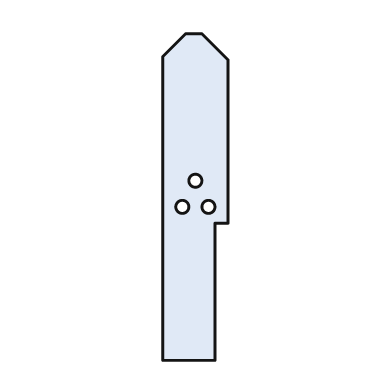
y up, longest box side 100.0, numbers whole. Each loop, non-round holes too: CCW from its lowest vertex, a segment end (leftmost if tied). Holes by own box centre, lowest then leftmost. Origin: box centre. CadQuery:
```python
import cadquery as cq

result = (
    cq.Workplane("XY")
    .moveTo(-10.0, -50.0)
    .lineTo(6.0, -50.0)
    .lineTo(6.0, -8.0)
    .lineTo(10.0, -8.0)
    .lineTo(10.0, 42.0)
    .lineTo(2.0, 50.0)
    .lineTo(-3.0, 50.0)
    .lineTo(-10.0, 43.0)
    .close()
    .moveTo(-4.0, -3.0)
    .circle(2.0)
    .moveTo(4.0, -3.0)
    .circle(2.0)
    .moveTo(0.0, 5.0)
    .circle(2.0)
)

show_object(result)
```